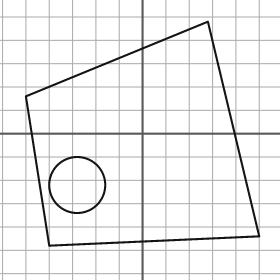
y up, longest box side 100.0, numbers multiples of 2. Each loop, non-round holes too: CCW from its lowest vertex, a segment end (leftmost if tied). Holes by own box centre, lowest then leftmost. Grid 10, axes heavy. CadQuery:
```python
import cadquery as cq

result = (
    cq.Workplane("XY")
    .moveTo(-40.0, -48.0)
    .lineTo(50.0, -44.0)
    .lineTo(28.0, 48.0)
    .lineTo(-50.0, 16.0)
    .close()
    .moveTo(-28.0, -22.0)
    .circle(12.0)
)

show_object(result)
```